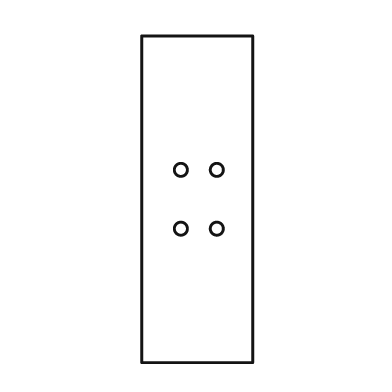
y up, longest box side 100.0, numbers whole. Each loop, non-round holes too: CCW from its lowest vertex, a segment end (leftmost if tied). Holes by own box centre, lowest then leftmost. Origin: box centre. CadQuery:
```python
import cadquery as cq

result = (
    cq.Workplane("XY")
    .moveTo(-17.0, -50.0)
    .lineTo(17.0, -50.0)
    .lineTo(17.0, 50.0)
    .lineTo(-17.0, 50.0)
    .close()
    .moveTo(-5.0, -9.0)
    .circle(2.0)
    .moveTo(6.0, -9.0)
    .circle(2.0)
    .moveTo(-5.0, 9.0)
    .circle(2.0)
    .moveTo(6.0, 9.0)
    .circle(2.0)
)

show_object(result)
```